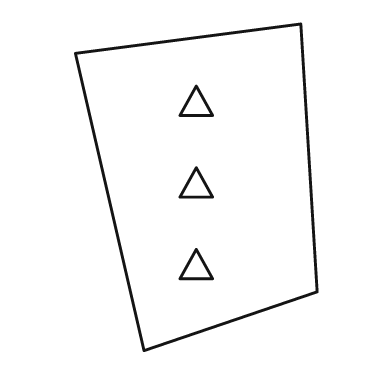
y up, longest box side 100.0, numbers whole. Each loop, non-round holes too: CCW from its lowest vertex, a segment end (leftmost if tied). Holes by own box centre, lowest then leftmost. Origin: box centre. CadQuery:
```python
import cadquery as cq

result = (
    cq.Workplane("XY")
    .moveTo(-16.0, -50.0)
    .lineTo(37.0, -32.0)
    .lineTo(32.0, 50.0)
    .lineTo(-37.0, 41.0)
    .close()
    .moveTo(-5.0, -28.0)
    .lineTo(5.0, -28.0)
    .lineTo(0.0, -19.0)
    .close()
    .moveTo(-5.0, -3.0)
    .lineTo(5.0, -3.0)
    .lineTo(0.0, 6.0)
    .close()
    .moveTo(-5.0, 22.0)
    .lineTo(5.0, 22.0)
    .lineTo(0.0, 31.0)
    .close()
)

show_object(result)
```